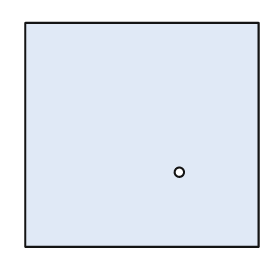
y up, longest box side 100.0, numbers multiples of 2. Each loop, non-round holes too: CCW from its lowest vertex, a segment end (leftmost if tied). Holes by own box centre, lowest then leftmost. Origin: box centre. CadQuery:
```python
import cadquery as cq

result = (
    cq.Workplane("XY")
    .moveTo(-50.0, -48.0)
    .lineTo(50.0, -48.0)
    .lineTo(50.0, 48.0)
    .lineTo(-50.0, 48.0)
    .close()
    .moveTo(16.0, -16.0)
    .circle(2.0)
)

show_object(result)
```